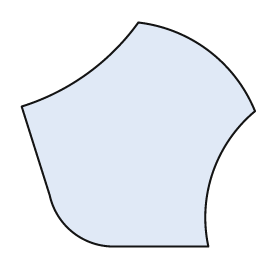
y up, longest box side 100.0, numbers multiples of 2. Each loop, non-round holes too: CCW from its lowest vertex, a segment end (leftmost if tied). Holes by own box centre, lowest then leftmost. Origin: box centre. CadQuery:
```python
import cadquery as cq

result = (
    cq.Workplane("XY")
    .moveTo(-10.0, -48.0)
    .lineTo(30.0, -48.0)
    .threePointArc((32.0, -16.0), (50.0, 10.0))
    .threePointArc((30.0, 36.0), (0.0, 48.0))
    .threePointArc((-22.0, 26.0), (-50.0, 12.0))
    .lineTo(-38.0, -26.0)
    .threePointArc((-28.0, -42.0), (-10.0, -48.0))
    .close()
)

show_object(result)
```